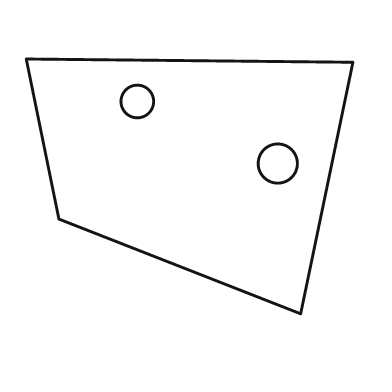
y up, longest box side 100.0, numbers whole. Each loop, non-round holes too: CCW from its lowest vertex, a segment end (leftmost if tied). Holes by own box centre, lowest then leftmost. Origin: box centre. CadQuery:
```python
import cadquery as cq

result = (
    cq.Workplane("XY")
    .moveTo(34.0, -39.0)
    .lineTo(50.0, 38.0)
    .lineTo(-50.0, 39.0)
    .lineTo(-40.0, -10.0)
    .close()
    .moveTo(27.0, 7.0)
    .circle(6.0)
    .moveTo(-16.0, 26.0)
    .circle(5.0)
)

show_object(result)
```